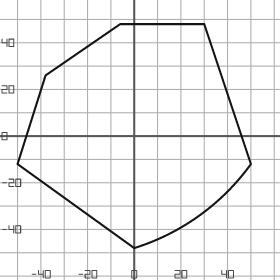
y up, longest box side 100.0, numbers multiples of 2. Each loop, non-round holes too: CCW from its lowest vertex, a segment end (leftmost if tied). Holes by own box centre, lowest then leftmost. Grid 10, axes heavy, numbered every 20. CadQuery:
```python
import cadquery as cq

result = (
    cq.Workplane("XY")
    .moveTo(0.0, -48.0)
    .threePointArc((28.0, -34.0), (50.0, -12.0))
    .lineTo(30.0, 48.0)
    .lineTo(-6.0, 48.0)
    .lineTo(-38.0, 26.0)
    .lineTo(-50.0, -12.0)
    .close()
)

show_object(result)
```